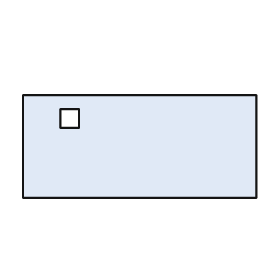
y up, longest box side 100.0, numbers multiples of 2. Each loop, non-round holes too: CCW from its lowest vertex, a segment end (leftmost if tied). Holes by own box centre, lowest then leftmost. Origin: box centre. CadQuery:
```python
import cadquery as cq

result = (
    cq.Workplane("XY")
    .moveTo(-50.0, -22.0)
    .lineTo(50.0, -22.0)
    .lineTo(50.0, 22.0)
    .lineTo(-50.0, 22.0)
    .close()
    .moveTo(-34.0, 8.0)
    .lineTo(-26.0, 8.0)
    .lineTo(-26.0, 16.0)
    .lineTo(-34.0, 16.0)
    .close()
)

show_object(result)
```